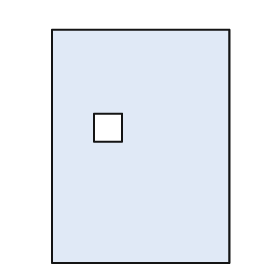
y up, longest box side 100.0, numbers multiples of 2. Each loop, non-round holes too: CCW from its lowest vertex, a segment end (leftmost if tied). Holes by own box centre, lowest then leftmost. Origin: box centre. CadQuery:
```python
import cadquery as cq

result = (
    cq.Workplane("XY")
    .moveTo(-38.0, -50.0)
    .lineTo(38.0, -50.0)
    .lineTo(38.0, 50.0)
    .lineTo(-38.0, 50.0)
    .close()
    .moveTo(-20.0, 2.0)
    .lineTo(-8.0, 2.0)
    .lineTo(-8.0, 14.0)
    .lineTo(-20.0, 14.0)
    .close()
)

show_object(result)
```